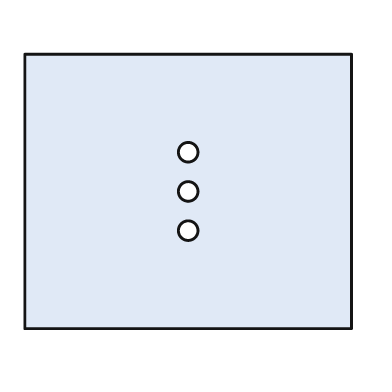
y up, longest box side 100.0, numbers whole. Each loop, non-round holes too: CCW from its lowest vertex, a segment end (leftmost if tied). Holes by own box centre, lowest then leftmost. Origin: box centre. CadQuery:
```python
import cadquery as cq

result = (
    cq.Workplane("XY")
    .moveTo(-50.0, -42.0)
    .lineTo(50.0, -42.0)
    .lineTo(50.0, 42.0)
    .lineTo(-50.0, 42.0)
    .close()
    .moveTo(0.0, -12.0)
    .circle(3.0)
    .moveTo(0.0, 0.0)
    .circle(3.0)
    .moveTo(0.0, 12.0)
    .circle(3.0)
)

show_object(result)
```